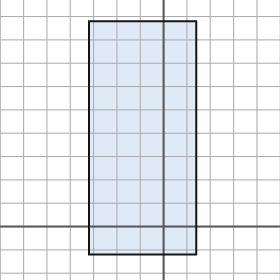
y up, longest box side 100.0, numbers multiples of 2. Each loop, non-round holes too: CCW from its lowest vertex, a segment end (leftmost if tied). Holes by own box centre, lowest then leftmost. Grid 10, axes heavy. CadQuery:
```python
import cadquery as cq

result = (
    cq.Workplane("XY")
    .moveTo(-32.0, -12.0)
    .lineTo(14.0, -12.0)
    .lineTo(14.0, 88.0)
    .lineTo(-32.0, 88.0)
    .close()
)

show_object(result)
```